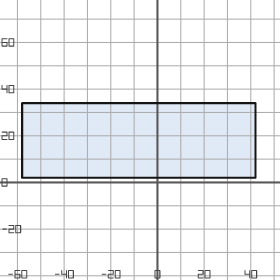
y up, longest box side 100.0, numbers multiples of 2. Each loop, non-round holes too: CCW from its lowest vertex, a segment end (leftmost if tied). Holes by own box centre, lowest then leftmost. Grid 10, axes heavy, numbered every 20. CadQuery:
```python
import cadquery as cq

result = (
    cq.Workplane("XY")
    .moveTo(-58.0, 2.0)
    .lineTo(42.0, 2.0)
    .lineTo(42.0, 34.0)
    .lineTo(-58.0, 34.0)
    .close()
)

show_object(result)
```